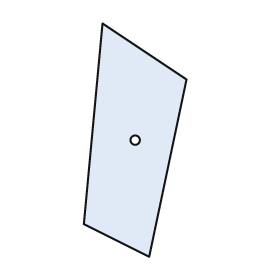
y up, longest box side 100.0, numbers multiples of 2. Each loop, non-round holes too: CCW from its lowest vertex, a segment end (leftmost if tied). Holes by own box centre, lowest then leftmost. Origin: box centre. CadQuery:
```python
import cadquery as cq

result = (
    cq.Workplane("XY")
    .moveTo(6.0, -50.0)
    .lineTo(22.0, 26.0)
    .lineTo(-14.0, 50.0)
    .lineTo(-22.0, -36.0)
    .close()
    .moveTo(0.0, 0.0)
    .circle(2.0)
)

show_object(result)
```